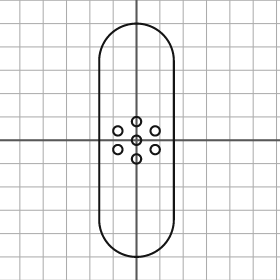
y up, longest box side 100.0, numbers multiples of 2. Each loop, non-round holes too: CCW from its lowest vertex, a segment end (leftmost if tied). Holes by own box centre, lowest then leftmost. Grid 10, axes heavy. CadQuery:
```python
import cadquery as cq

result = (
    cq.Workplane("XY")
    .moveTo(-16.0, -34.0)
    .threePointArc((0.0, -50.0), (16.0, -34.0))
    .lineTo(16.0, 34.0)
    .threePointArc((0.0, 50.0), (-16.0, 34.0))
    .close()
    .moveTo(0.0, -8.0)
    .circle(2.0)
    .moveTo(-8.0, -4.0)
    .circle(2.0)
    .moveTo(8.0, -4.0)
    .circle(2.0)
    .moveTo(0.0, 0.0)
    .circle(2.0)
    .moveTo(-8.0, 4.0)
    .circle(2.0)
    .moveTo(8.0, 4.0)
    .circle(2.0)
    .moveTo(0.0, 8.0)
    .circle(2.0)
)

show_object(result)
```